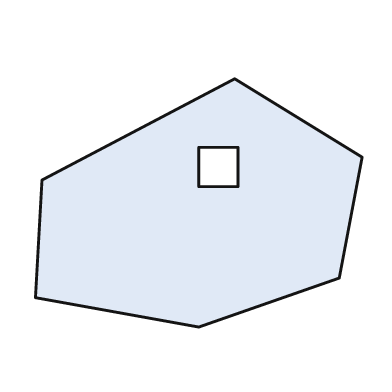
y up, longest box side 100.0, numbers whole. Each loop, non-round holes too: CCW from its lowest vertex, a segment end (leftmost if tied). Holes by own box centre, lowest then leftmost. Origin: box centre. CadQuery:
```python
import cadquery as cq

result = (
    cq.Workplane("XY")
    .moveTo(0.0, -38.0)
    .lineTo(43.0, -23.0)
    .lineTo(50.0, 14.0)
    .lineTo(11.0, 38.0)
    .lineTo(-48.0, 7.0)
    .lineTo(-50.0, -29.0)
    .close()
    .moveTo(0.0, 5.0)
    .lineTo(12.0, 5.0)
    .lineTo(12.0, 17.0)
    .lineTo(0.0, 17.0)
    .close()
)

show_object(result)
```